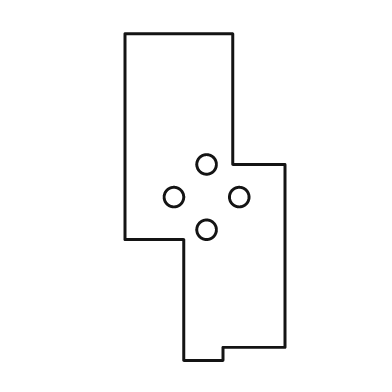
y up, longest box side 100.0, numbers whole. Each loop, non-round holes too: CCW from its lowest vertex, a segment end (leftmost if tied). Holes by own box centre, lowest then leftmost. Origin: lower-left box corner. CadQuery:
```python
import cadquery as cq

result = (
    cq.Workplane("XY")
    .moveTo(18.0, 0.0)
    .lineTo(30.0, 0.0)
    .lineTo(30.0, 4.0)
    .lineTo(49.0, 4.0)
    .lineTo(49.0, 60.0)
    .lineTo(33.0, 60.0)
    .lineTo(33.0, 100.0)
    .lineTo(0.0, 100.0)
    .lineTo(0.0, 37.0)
    .lineTo(18.0, 37.0)
    .close()
    .moveTo(25.0, 40.0)
    .circle(3.0)
    .moveTo(15.0, 50.0)
    .circle(3.0)
    .moveTo(35.0, 50.0)
    .circle(3.0)
    .moveTo(25.0, 60.0)
    .circle(3.0)
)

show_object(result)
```